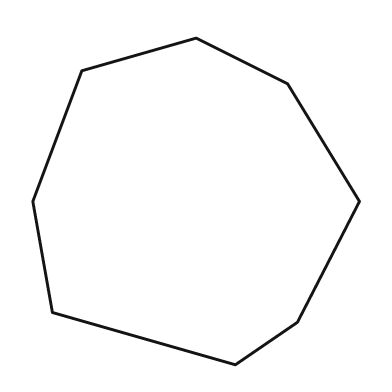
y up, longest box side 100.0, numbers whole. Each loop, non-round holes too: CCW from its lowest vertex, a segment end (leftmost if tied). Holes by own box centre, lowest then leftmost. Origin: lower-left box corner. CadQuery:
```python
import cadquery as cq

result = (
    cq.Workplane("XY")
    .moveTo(62.0, 0.0)
    .lineTo(81.0, 13.0)
    .lineTo(100.0, 50.0)
    .lineTo(78.0, 86.0)
    .lineTo(50.0, 100.0)
    .lineTo(15.0, 90.0)
    .lineTo(0.0, 50.0)
    .lineTo(6.0, 16.0)
    .close()
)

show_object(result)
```